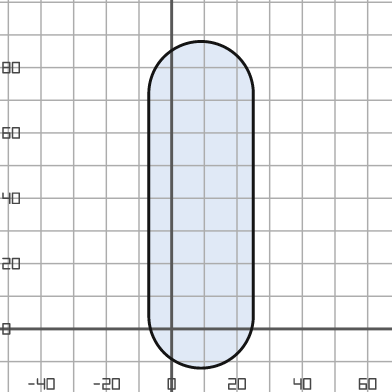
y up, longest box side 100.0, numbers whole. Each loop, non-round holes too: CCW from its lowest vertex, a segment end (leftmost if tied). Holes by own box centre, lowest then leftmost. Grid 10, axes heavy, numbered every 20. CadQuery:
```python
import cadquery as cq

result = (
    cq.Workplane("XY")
    .moveTo(-7.0, 4.0)
    .threePointArc((9.0, -12.0), (25.0, 4.0))
    .lineTo(25.0, 72.0)
    .threePointArc((9.0, 88.0), (-7.0, 72.0))
    .close()
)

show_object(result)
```